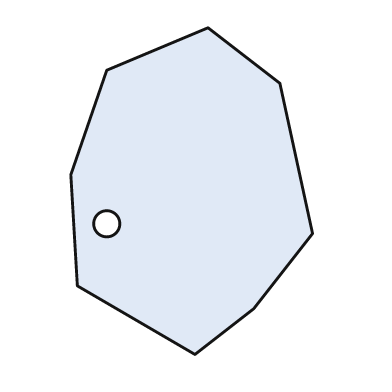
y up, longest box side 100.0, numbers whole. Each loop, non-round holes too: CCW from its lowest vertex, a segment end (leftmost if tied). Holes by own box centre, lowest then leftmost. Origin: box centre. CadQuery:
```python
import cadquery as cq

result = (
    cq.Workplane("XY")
    .moveTo(1.0, -50.0)
    .lineTo(19.0, -36.0)
    .lineTo(37.0, -13.0)
    .lineTo(27.0, 33.0)
    .lineTo(5.0, 50.0)
    .lineTo(-26.0, 37.0)
    .lineTo(-37.0, 5.0)
    .lineTo(-35.0, -29.0)
    .close()
    .moveTo(-26.0, -10.0)
    .circle(4.0)
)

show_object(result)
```